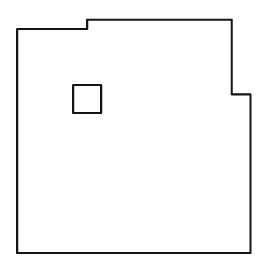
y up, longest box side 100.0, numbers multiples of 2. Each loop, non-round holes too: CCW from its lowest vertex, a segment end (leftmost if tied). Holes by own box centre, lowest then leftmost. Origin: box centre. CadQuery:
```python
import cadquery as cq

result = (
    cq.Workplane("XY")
    .moveTo(-50.0, -50.0)
    .lineTo(50.0, -50.0)
    .lineTo(50.0, 18.0)
    .lineTo(42.0, 18.0)
    .lineTo(42.0, 50.0)
    .lineTo(-20.0, 50.0)
    .lineTo(-20.0, 46.0)
    .lineTo(-50.0, 46.0)
    .close()
    .moveTo(-26.0, 10.0)
    .lineTo(-14.0, 10.0)
    .lineTo(-14.0, 22.0)
    .lineTo(-26.0, 22.0)
    .close()
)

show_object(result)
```